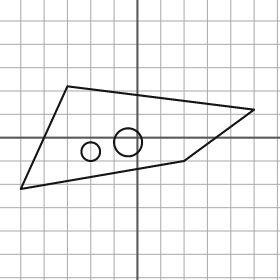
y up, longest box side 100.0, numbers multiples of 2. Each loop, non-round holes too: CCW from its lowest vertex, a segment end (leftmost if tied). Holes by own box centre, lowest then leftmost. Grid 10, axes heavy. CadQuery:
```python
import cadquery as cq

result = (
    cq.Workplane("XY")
    .moveTo(-50.0, -22.0)
    .lineTo(20.0, -10.0)
    .lineTo(50.0, 12.0)
    .lineTo(-30.0, 22.0)
    .close()
    .moveTo(-20.0, -6.0)
    .circle(4.0)
    .moveTo(-4.0, -2.0)
    .circle(6.0)
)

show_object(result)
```